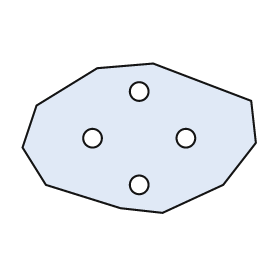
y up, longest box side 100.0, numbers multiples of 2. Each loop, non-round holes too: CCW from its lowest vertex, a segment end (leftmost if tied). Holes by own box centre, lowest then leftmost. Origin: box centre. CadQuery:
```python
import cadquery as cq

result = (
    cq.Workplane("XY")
    .moveTo(10.0, -32.0)
    .lineTo(36.0, -20.0)
    .lineTo(50.0, -2.0)
    .lineTo(48.0, 16.0)
    .lineTo(6.0, 32.0)
    .lineTo(-18.0, 30.0)
    .lineTo(-44.0, 14.0)
    .lineTo(-50.0, -4.0)
    .lineTo(-40.0, -20.0)
    .lineTo(-8.0, -30.0)
    .close()
    .moveTo(0.0, -20.0)
    .circle(4.0)
    .moveTo(-20.0, 0.0)
    .circle(4.0)
    .moveTo(20.0, 0.0)
    .circle(4.0)
    .moveTo(0.0, 20.0)
    .circle(4.0)
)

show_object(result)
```